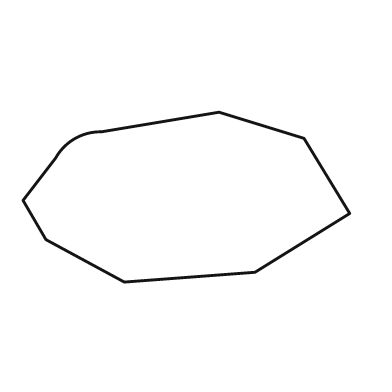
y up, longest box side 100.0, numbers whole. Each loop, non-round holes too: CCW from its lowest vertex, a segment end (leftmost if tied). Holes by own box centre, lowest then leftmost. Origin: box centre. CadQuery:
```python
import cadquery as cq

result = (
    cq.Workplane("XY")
    .moveTo(-19.0, -26.0)
    .lineTo(21.0, -23.0)
    .lineTo(50.0, -5.0)
    .lineTo(36.0, 18.0)
    .lineTo(10.0, 26.0)
    .lineTo(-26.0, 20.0)
    .threePointArc((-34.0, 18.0), (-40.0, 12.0))
    .lineTo(-50.0, -1.0)
    .lineTo(-43.0, -13.0)
    .close()
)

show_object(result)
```